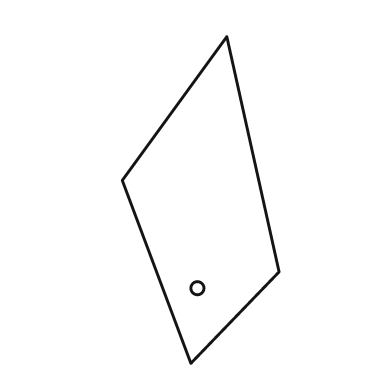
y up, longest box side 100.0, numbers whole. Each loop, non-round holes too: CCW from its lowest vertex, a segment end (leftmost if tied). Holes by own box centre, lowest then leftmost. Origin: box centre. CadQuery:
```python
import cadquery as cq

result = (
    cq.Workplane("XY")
    .moveTo(-3.0, -50.0)
    .lineTo(24.0, -22.0)
    .lineTo(8.0, 50.0)
    .lineTo(-24.0, 6.0)
    .close()
    .moveTo(-1.0, -27.0)
    .circle(2.0)
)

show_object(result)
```